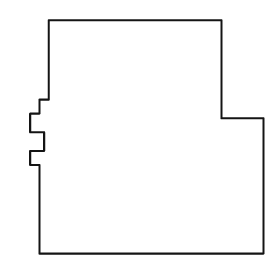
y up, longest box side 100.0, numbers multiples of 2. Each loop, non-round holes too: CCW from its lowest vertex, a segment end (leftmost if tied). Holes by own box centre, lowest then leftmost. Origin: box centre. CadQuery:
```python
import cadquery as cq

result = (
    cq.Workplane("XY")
    .moveTo(-46.0, -50.0)
    .lineTo(50.0, -50.0)
    .lineTo(50.0, 8.0)
    .lineTo(32.0, 8.0)
    .lineTo(32.0, 50.0)
    .lineTo(-42.0, 50.0)
    .lineTo(-42.0, 16.0)
    .lineTo(-46.0, 16.0)
    .lineTo(-46.0, 10.0)
    .lineTo(-50.0, 10.0)
    .lineTo(-50.0, 2.0)
    .lineTo(-44.0, 2.0)
    .lineTo(-44.0, -6.0)
    .lineTo(-50.0, -6.0)
    .lineTo(-50.0, -12.0)
    .lineTo(-46.0, -12.0)
    .close()
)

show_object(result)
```